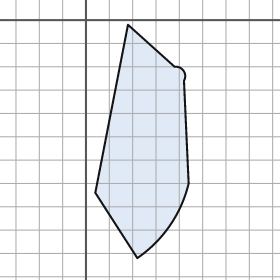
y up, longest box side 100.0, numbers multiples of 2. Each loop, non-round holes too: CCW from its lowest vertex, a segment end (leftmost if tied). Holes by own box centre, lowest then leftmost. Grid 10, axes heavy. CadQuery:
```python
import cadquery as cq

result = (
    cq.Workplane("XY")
    .moveTo(22.0, -102.0)
    .threePointArc((36.0, -88.0), (44.0, -70.0))
    .lineTo(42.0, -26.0)
    .threePointArc((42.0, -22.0), (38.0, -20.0))
    .lineTo(18.0, -2.0)
    .lineTo(4.0, -74.0)
    .close()
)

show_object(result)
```